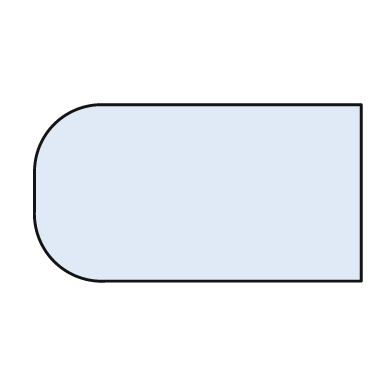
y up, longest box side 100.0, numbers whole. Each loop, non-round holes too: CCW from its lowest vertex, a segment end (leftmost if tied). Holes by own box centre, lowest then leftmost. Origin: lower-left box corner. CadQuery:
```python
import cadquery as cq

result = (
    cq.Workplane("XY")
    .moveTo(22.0, 0.0)
    .lineTo(100.0, 0.0)
    .lineTo(100.0, 54.0)
    .lineTo(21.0, 54.0)
    .threePointArc((6.0, 48.0), (0.0, 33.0))
    .lineTo(0.0, 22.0)
    .threePointArc((6.0, 6.0), (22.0, 0.0))
    .close()
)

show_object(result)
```